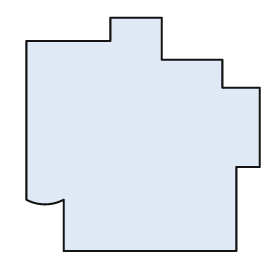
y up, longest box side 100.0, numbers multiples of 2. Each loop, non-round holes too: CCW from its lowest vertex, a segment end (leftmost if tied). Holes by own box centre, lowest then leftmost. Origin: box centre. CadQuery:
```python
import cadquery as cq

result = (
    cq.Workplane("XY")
    .moveTo(-34.0, -50.0)
    .lineTo(40.0, -50.0)
    .lineTo(40.0, -14.0)
    .lineTo(50.0, -14.0)
    .lineTo(50.0, 20.0)
    .lineTo(34.0, 20.0)
    .lineTo(34.0, 32.0)
    .lineTo(8.0, 32.0)
    .lineTo(8.0, 50.0)
    .lineTo(-14.0, 50.0)
    .lineTo(-14.0, 40.0)
    .lineTo(-50.0, 40.0)
    .lineTo(-50.0, -28.0)
    .threePointArc((-42.0, -30.0), (-34.0, -28.0))
    .close()
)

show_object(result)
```